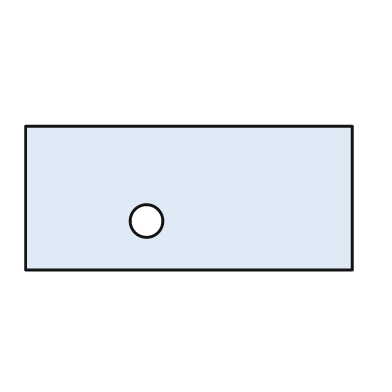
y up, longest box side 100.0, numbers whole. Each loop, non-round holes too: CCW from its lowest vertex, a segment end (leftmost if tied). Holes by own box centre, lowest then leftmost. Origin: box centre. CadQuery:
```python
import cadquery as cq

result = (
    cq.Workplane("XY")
    .moveTo(-50.0, -22.0)
    .lineTo(50.0, -22.0)
    .lineTo(50.0, 22.0)
    .lineTo(-50.0, 22.0)
    .close()
    .moveTo(-13.0, -7.0)
    .circle(5.0)
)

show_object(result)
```